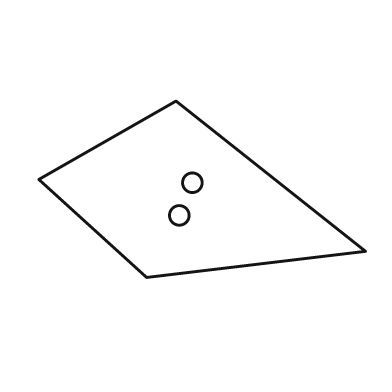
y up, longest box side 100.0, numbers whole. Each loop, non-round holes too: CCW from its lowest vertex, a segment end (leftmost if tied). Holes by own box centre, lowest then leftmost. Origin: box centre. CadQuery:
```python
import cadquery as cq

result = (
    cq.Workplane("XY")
    .moveTo(-17.0, -27.0)
    .lineTo(50.0, -19.0)
    .lineTo(-8.0, 27.0)
    .lineTo(-50.0, 3.0)
    .close()
    .moveTo(-7.0, -8.0)
    .circle(3.0)
    .moveTo(-3.0, 2.0)
    .circle(3.0)
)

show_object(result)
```